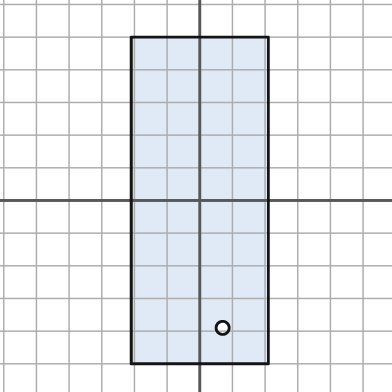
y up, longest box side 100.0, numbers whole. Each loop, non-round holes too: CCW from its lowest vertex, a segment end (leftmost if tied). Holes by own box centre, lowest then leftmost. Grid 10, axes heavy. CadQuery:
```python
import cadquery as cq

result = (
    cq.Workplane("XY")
    .moveTo(-21.0, -50.0)
    .lineTo(21.0, -50.0)
    .lineTo(21.0, 50.0)
    .lineTo(-21.0, 50.0)
    .close()
    .moveTo(7.0, -39.0)
    .circle(2.0)
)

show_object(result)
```